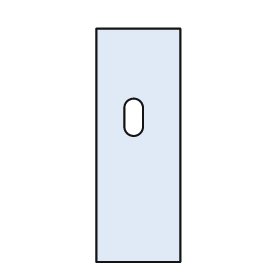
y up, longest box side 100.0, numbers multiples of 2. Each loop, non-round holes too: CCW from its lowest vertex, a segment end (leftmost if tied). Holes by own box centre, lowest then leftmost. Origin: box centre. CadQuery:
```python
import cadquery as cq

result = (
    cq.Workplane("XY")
    .moveTo(-18.0, -50.0)
    .lineTo(18.0, -50.0)
    .lineTo(18.0, 50.0)
    .lineTo(-18.0, 50.0)
    .close()
    .moveTo(-6.0, 8.0)
    .threePointArc((-2.0, 4.0), (2.0, 8.0))
    .lineTo(2.0, 16.0)
    .threePointArc((-2.0, 20.0), (-6.0, 16.0))
    .close()
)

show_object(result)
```